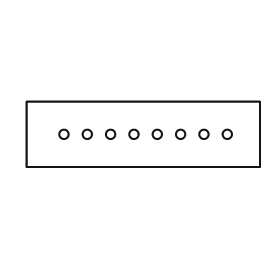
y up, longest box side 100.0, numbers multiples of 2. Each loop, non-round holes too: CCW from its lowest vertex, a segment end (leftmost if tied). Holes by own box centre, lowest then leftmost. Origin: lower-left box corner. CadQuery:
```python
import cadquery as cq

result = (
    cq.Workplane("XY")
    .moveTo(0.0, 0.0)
    .lineTo(100.0, 0.0)
    .lineTo(100.0, 28.0)
    .lineTo(0.0, 28.0)
    .close()
    .moveTo(16.0, 14.0)
    .circle(2.0)
    .moveTo(26.0, 14.0)
    .circle(2.0)
    .moveTo(36.0, 14.0)
    .circle(2.0)
    .moveTo(46.0, 14.0)
    .circle(2.0)
    .moveTo(56.0, 14.0)
    .circle(2.0)
    .moveTo(66.0, 14.0)
    .circle(2.0)
    .moveTo(76.0, 14.0)
    .circle(2.0)
    .moveTo(86.0, 14.0)
    .circle(2.0)
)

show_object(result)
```